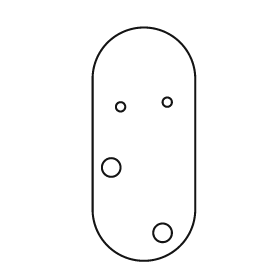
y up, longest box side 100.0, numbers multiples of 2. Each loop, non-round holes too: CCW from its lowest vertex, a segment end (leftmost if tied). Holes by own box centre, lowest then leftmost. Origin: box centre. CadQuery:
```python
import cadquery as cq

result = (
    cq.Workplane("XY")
    .moveTo(-22.0, -28.0)
    .threePointArc((0.0, -50.0), (22.0, -28.0))
    .lineTo(22.0, 28.0)
    .threePointArc((0.0, 50.0), (-22.0, 28.0))
    .close()
    .moveTo(8.0, -38.0)
    .circle(4.0)
    .moveTo(-14.0, -10.0)
    .circle(4.0)
    .moveTo(-10.0, 16.0)
    .circle(2.0)
    .moveTo(10.0, 18.0)
    .circle(2.0)
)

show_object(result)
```